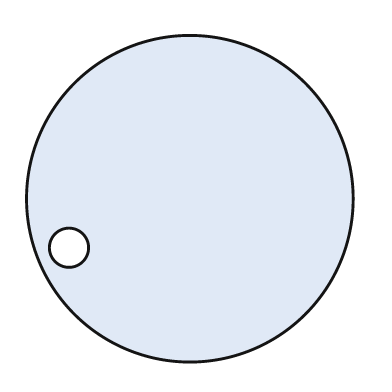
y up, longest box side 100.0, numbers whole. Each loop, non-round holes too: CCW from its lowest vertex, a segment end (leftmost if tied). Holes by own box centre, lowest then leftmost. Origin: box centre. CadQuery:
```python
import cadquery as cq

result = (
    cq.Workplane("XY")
    .moveTo(0.0, 0.0)
    .circle(50.0)
    .moveTo(-37.0, -15.0)
    .circle(6.0)
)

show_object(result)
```